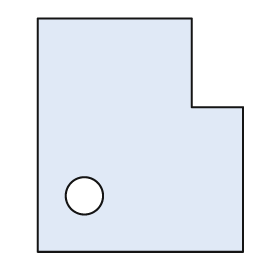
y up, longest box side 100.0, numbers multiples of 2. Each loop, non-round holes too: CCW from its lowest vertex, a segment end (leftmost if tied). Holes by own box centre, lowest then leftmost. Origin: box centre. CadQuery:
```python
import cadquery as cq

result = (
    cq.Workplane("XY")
    .moveTo(-44.0, -50.0)
    .lineTo(44.0, -50.0)
    .lineTo(44.0, 12.0)
    .lineTo(22.0, 12.0)
    .lineTo(22.0, 50.0)
    .lineTo(-44.0, 50.0)
    .close()
    .moveTo(-24.0, -26.0)
    .circle(8.0)
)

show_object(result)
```